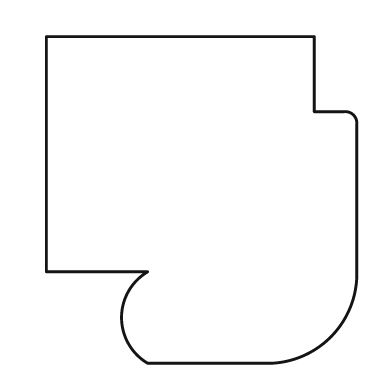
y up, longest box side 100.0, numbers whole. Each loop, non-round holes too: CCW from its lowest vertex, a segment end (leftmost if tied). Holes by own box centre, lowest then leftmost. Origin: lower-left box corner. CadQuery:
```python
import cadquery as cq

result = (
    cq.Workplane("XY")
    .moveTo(31.0, 0.0)
    .lineTo(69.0, 0.0)
    .threePointArc((87.0, 8.0), (95.0, 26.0))
    .lineTo(95.0, 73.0)
    .threePointArc((94.0, 76.0), (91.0, 77.0))
    .lineTo(82.0, 77.0)
    .lineTo(82.0, 100.0)
    .lineTo(0.0, 100.0)
    .lineTo(0.0, 28.0)
    .lineTo(31.0, 28.0)
    .threePointArc((23.0, 14.0), (31.0, 0.0))
    .close()
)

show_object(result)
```